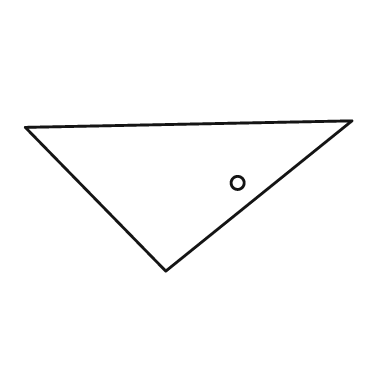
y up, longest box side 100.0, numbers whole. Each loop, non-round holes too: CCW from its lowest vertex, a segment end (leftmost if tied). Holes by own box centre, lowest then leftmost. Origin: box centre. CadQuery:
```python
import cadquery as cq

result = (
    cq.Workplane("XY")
    .moveTo(-7.0, -23.0)
    .lineTo(50.0, 23.0)
    .lineTo(-50.0, 21.0)
    .close()
    .moveTo(15.0, 4.0)
    .circle(2.0)
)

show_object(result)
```